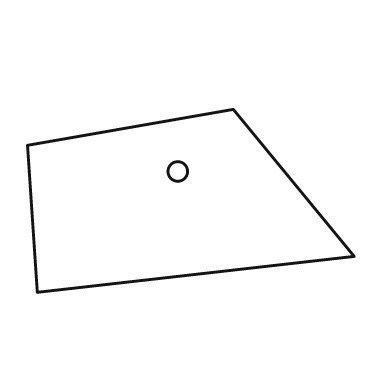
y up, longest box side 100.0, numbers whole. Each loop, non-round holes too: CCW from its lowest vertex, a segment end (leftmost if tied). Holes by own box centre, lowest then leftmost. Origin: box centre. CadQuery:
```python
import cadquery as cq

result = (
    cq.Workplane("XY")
    .moveTo(-47.0, -28.0)
    .lineTo(50.0, -17.0)
    .lineTo(13.0, 28.0)
    .lineTo(-50.0, 17.0)
    .close()
    .moveTo(-4.0, 9.0)
    .circle(3.0)
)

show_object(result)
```